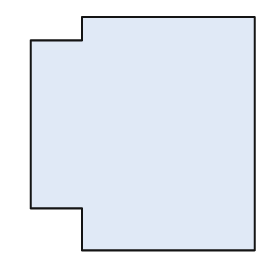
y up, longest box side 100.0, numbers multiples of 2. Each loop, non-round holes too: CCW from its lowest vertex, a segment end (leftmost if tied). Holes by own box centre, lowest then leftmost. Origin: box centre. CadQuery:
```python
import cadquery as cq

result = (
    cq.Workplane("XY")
    .moveTo(-26.0, -50.0)
    .lineTo(48.0, -50.0)
    .lineTo(48.0, 50.0)
    .lineTo(-26.0, 50.0)
    .lineTo(-26.0, 40.0)
    .lineTo(-48.0, 40.0)
    .lineTo(-48.0, -32.0)
    .lineTo(-26.0, -32.0)
    .close()
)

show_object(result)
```